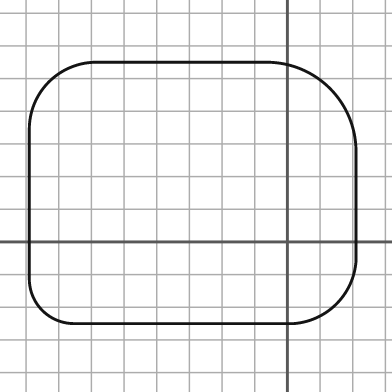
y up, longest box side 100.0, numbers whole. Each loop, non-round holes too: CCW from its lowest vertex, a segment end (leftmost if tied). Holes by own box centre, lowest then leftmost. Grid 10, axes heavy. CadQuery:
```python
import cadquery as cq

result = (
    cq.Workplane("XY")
    .moveTo(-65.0, -25.0)
    .lineTo(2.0, -25.0)
    .threePointArc((15.0, -19.0), (21.0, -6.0))
    .lineTo(21.0, 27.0)
    .threePointArc((13.0, 47.0), (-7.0, 55.0))
    .lineTo(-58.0, 55.0)
    .threePointArc((-73.0, 49.0), (-79.0, 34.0))
    .lineTo(-79.0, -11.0)
    .threePointArc((-75.0, -21.0), (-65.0, -25.0))
    .close()
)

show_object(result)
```